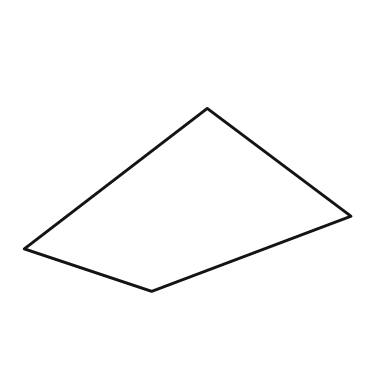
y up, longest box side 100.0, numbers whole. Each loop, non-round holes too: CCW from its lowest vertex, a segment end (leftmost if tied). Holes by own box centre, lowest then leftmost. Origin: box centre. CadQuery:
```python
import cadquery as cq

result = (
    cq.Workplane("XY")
    .moveTo(-11.0, -28.0)
    .lineTo(50.0, -5.0)
    .lineTo(6.0, 28.0)
    .lineTo(-50.0, -15.0)
    .close()
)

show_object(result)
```